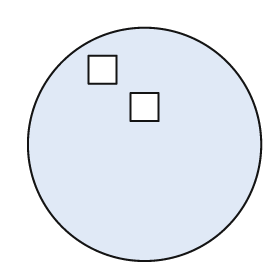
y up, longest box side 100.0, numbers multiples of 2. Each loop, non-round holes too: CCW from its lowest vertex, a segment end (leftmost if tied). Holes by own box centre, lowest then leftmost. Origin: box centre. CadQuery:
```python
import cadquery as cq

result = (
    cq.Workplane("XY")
    .moveTo(0.0, 0.0)
    .circle(50.0)
    .moveTo(-6.0, 10.0)
    .lineTo(6.0, 10.0)
    .lineTo(6.0, 22.0)
    .lineTo(-6.0, 22.0)
    .close()
    .moveTo(-24.0, 26.0)
    .lineTo(-12.0, 26.0)
    .lineTo(-12.0, 38.0)
    .lineTo(-24.0, 38.0)
    .close()
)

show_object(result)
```